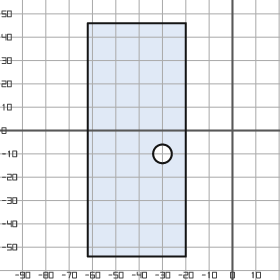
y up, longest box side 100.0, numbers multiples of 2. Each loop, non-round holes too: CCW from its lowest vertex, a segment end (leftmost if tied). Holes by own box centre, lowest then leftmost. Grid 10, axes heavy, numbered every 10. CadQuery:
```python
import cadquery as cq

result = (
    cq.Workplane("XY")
    .moveTo(-62.0, -54.0)
    .lineTo(-20.0, -54.0)
    .lineTo(-20.0, 46.0)
    .lineTo(-62.0, 46.0)
    .close()
    .moveTo(-30.0, -10.0)
    .circle(4.0)
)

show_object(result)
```